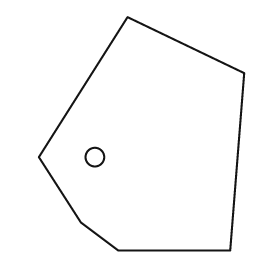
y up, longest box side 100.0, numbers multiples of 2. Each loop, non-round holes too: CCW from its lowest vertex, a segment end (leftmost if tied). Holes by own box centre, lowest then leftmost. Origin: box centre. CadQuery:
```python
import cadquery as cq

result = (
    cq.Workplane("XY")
    .moveTo(-10.0, -50.0)
    .lineTo(38.0, -50.0)
    .lineTo(44.0, 26.0)
    .lineTo(-6.0, 50.0)
    .lineTo(-44.0, -10.0)
    .lineTo(-26.0, -38.0)
    .close()
    .moveTo(-20.0, -10.0)
    .circle(4.0)
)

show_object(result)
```